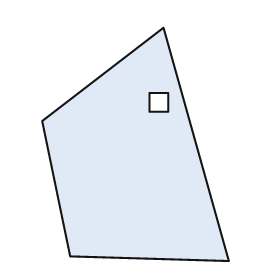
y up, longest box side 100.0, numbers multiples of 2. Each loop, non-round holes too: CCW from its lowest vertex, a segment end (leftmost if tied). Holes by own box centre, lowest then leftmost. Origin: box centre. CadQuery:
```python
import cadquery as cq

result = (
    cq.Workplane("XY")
    .moveTo(40.0, -50.0)
    .lineTo(12.0, 50.0)
    .lineTo(-40.0, 10.0)
    .lineTo(-28.0, -48.0)
    .close()
    .moveTo(6.0, 14.0)
    .lineTo(14.0, 14.0)
    .lineTo(14.0, 22.0)
    .lineTo(6.0, 22.0)
    .close()
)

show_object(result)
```